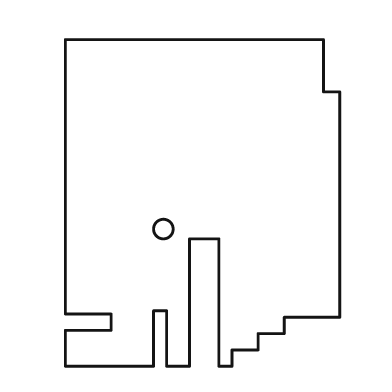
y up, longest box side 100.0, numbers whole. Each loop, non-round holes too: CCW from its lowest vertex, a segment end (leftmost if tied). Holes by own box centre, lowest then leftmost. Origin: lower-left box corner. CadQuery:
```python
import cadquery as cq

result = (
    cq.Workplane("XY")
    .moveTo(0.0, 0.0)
    .lineTo(27.0, 0.0)
    .lineTo(27.0, 17.0)
    .lineTo(31.0, 17.0)
    .lineTo(31.0, 0.0)
    .lineTo(38.0, 0.0)
    .lineTo(38.0, 39.0)
    .lineTo(47.0, 39.0)
    .lineTo(47.0, 0.0)
    .lineTo(51.0, 0.0)
    .lineTo(51.0, 5.0)
    .lineTo(59.0, 5.0)
    .lineTo(59.0, 10.0)
    .lineTo(67.0, 10.0)
    .lineTo(67.0, 15.0)
    .lineTo(84.0, 15.0)
    .lineTo(84.0, 84.0)
    .lineTo(79.0, 84.0)
    .lineTo(79.0, 100.0)
    .lineTo(0.0, 100.0)
    .lineTo(0.0, 16.0)
    .lineTo(14.0, 16.0)
    .lineTo(14.0, 11.0)
    .lineTo(0.0, 11.0)
    .close()
    .moveTo(30.0, 42.0)
    .circle(3.0)
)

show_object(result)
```